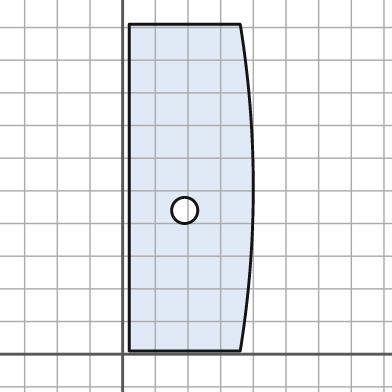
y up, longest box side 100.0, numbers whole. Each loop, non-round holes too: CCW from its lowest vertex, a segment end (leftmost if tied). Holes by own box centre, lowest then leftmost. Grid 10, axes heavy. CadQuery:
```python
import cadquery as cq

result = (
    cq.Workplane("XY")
    .moveTo(2.0, 1.0)
    .lineTo(36.0, 1.0)
    .threePointArc((40.0, 51.0), (36.0, 101.0))
    .lineTo(2.0, 101.0)
    .close()
    .moveTo(19.0, 44.0)
    .circle(4.0)
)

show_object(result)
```